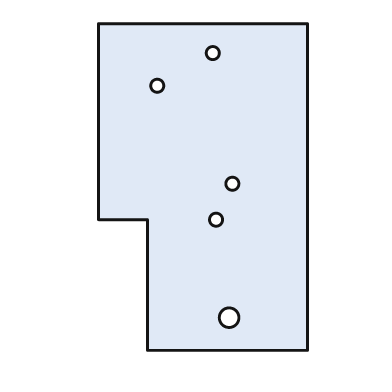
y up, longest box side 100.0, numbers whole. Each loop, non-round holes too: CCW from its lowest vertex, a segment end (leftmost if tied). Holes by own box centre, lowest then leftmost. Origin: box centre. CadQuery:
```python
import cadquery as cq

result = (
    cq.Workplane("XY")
    .moveTo(-17.0, -50.0)
    .lineTo(32.0, -50.0)
    .lineTo(32.0, 50.0)
    .lineTo(-32.0, 50.0)
    .lineTo(-32.0, -10.0)
    .lineTo(-17.0, -10.0)
    .close()
    .moveTo(8.0, -40.0)
    .circle(3.0)
    .moveTo(4.0, -10.0)
    .circle(2.0)
    .moveTo(9.0, 1.0)
    .circle(2.0)
    .moveTo(-14.0, 31.0)
    .circle(2.0)
    .moveTo(3.0, 41.0)
    .circle(2.0)
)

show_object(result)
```